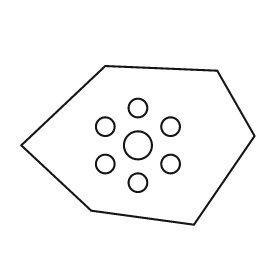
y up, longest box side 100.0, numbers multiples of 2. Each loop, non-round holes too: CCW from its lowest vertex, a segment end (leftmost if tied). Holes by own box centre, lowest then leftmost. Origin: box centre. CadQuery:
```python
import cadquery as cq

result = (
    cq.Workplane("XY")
    .moveTo(24.0, -34.0)
    .lineTo(50.0, 4.0)
    .lineTo(34.0, 32.0)
    .lineTo(-14.0, 34.0)
    .lineTo(-50.0, 0.0)
    .lineTo(-20.0, -28.0)
    .close()
    .moveTo(0.0, -16.0)
    .circle(4.0)
    .moveTo(-14.0, -8.0)
    .circle(4.0)
    .moveTo(14.0, -8.0)
    .circle(4.0)
    .moveTo(0.0, 0.0)
    .circle(6.0)
    .moveTo(-14.0, 8.0)
    .circle(4.0)
    .moveTo(14.0, 8.0)
    .circle(4.0)
    .moveTo(0.0, 16.0)
    .circle(4.0)
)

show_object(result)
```